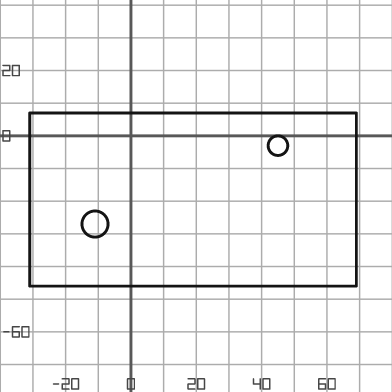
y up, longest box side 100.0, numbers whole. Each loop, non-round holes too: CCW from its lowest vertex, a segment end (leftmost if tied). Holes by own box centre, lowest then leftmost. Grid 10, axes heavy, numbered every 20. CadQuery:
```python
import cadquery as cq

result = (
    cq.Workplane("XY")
    .moveTo(-31.0, -46.0)
    .lineTo(69.0, -46.0)
    .lineTo(69.0, 7.0)
    .lineTo(-31.0, 7.0)
    .close()
    .moveTo(-11.0, -27.0)
    .circle(4.0)
    .moveTo(45.0, -3.0)
    .circle(3.0)
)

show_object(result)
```